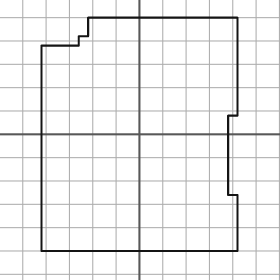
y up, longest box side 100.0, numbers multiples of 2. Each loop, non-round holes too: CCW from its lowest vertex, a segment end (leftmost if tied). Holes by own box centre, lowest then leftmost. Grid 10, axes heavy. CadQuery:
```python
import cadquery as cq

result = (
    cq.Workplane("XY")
    .moveTo(-42.0, -50.0)
    .lineTo(42.0, -50.0)
    .lineTo(42.0, -26.0)
    .lineTo(38.0, -26.0)
    .lineTo(38.0, 8.0)
    .lineTo(42.0, 8.0)
    .lineTo(42.0, 50.0)
    .lineTo(-22.0, 50.0)
    .lineTo(-22.0, 42.0)
    .lineTo(-26.0, 42.0)
    .lineTo(-26.0, 38.0)
    .lineTo(-42.0, 38.0)
    .close()
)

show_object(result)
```